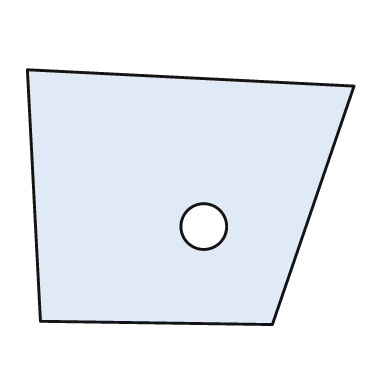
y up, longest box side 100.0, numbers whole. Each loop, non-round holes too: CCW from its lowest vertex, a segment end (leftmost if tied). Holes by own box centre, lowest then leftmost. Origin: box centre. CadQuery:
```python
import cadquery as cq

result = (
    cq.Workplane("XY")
    .moveTo(25.0, -39.0)
    .lineTo(50.0, 34.0)
    .lineTo(-50.0, 39.0)
    .lineTo(-46.0, -38.0)
    .close()
    .moveTo(4.0, -9.0)
    .circle(7.0)
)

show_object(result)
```